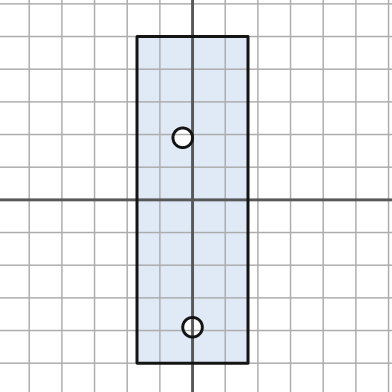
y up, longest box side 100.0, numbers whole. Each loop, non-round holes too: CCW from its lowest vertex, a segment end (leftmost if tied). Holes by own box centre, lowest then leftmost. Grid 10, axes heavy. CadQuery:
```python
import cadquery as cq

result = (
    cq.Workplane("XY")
    .moveTo(-17.0, -50.0)
    .lineTo(17.0, -50.0)
    .lineTo(17.0, 50.0)
    .lineTo(-17.0, 50.0)
    .close()
    .moveTo(0.0, -39.0)
    .circle(3.0)
    .moveTo(-3.0, 19.0)
    .circle(3.0)
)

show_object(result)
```